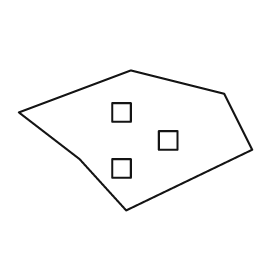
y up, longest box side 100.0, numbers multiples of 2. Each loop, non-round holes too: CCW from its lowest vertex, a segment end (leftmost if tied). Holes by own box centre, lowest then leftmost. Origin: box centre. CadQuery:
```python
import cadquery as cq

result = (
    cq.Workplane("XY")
    .moveTo(-4.0, -30.0)
    .lineTo(50.0, -4.0)
    .lineTo(38.0, 20.0)
    .lineTo(-2.0, 30.0)
    .lineTo(-50.0, 12.0)
    .lineTo(-24.0, -8.0)
    .close()
    .moveTo(-10.0, -16.0)
    .lineTo(-2.0, -16.0)
    .lineTo(-2.0, -8.0)
    .lineTo(-10.0, -8.0)
    .close()
    .moveTo(10.0, -4.0)
    .lineTo(18.0, -4.0)
    .lineTo(18.0, 4.0)
    .lineTo(10.0, 4.0)
    .close()
    .moveTo(-10.0, 8.0)
    .lineTo(-2.0, 8.0)
    .lineTo(-2.0, 16.0)
    .lineTo(-10.0, 16.0)
    .close()
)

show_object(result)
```